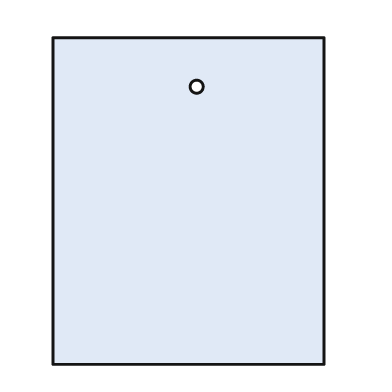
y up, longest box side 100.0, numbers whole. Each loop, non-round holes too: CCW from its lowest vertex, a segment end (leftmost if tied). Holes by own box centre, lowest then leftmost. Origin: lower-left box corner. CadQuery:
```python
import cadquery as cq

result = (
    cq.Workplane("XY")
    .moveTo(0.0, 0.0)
    .lineTo(83.0, 0.0)
    .lineTo(83.0, 100.0)
    .lineTo(0.0, 100.0)
    .close()
    .moveTo(44.0, 85.0)
    .circle(2.0)
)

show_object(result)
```